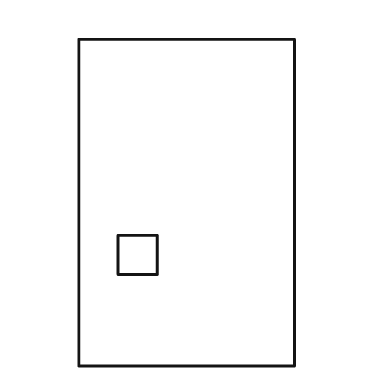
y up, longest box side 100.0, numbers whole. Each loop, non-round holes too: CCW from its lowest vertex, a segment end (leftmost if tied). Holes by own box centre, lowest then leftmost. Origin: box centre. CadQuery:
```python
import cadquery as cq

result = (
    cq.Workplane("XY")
    .moveTo(-33.0, -50.0)
    .lineTo(33.0, -50.0)
    .lineTo(33.0, 50.0)
    .lineTo(-33.0, 50.0)
    .close()
    .moveTo(-21.0, -22.0)
    .lineTo(-9.0, -22.0)
    .lineTo(-9.0, -10.0)
    .lineTo(-21.0, -10.0)
    .close()
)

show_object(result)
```